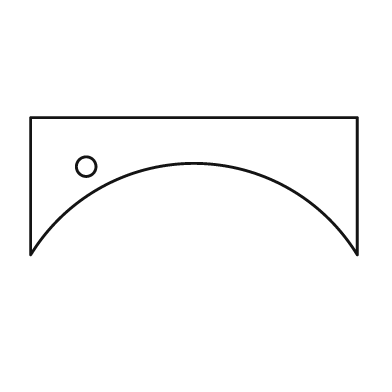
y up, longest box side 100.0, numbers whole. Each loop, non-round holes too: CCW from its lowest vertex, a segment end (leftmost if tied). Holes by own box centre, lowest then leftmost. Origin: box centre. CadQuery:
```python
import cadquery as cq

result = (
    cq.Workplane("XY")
    .moveTo(-50.0, -21.0)
    .threePointArc((0.0, 7.0), (50.0, -21.0))
    .lineTo(50.0, 21.0)
    .lineTo(-50.0, 21.0)
    .close()
    .moveTo(-33.0, 6.0)
    .circle(3.0)
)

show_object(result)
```